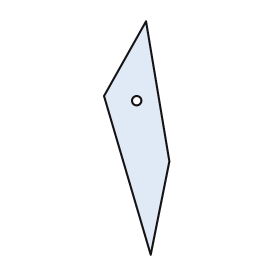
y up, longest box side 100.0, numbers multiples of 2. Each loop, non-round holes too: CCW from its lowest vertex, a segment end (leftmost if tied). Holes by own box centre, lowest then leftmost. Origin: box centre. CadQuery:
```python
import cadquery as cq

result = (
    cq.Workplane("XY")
    .moveTo(6.0, -50.0)
    .lineTo(14.0, -10.0)
    .lineTo(4.0, 50.0)
    .lineTo(-14.0, 18.0)
    .close()
    .moveTo(0.0, 16.0)
    .circle(2.0)
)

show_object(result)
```